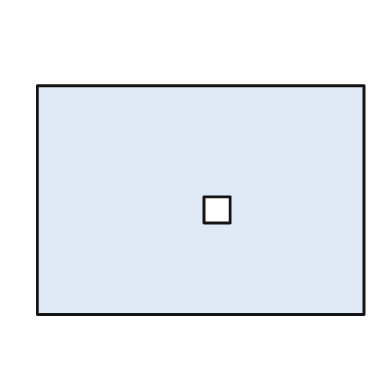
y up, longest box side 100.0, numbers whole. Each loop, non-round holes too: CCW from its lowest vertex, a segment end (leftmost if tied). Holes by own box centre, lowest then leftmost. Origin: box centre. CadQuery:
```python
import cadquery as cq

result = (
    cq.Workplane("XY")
    .moveTo(-50.0, -35.0)
    .lineTo(50.0, -35.0)
    .lineTo(50.0, 35.0)
    .lineTo(-50.0, 35.0)
    .close()
    .moveTo(1.0, -7.0)
    .lineTo(9.0, -7.0)
    .lineTo(9.0, 1.0)
    .lineTo(1.0, 1.0)
    .close()
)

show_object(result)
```